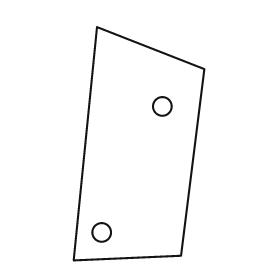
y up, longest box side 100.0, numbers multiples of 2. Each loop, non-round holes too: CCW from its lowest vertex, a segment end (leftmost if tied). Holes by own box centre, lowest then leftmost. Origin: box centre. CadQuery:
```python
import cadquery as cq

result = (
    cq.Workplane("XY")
    .moveTo(-28.0, -50.0)
    .lineTo(18.0, -48.0)
    .lineTo(28.0, 32.0)
    .lineTo(-18.0, 50.0)
    .close()
    .moveTo(-16.0, -38.0)
    .circle(4.0)
    .moveTo(10.0, 16.0)
    .circle(4.0)
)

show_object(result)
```